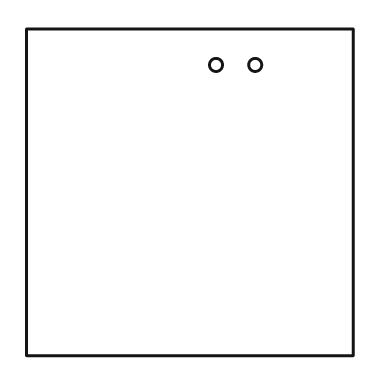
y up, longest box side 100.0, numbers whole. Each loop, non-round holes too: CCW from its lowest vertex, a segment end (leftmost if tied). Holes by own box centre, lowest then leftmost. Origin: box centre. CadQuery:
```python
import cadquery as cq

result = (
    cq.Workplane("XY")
    .moveTo(-50.0, -50.0)
    .lineTo(50.0, -50.0)
    .lineTo(50.0, 50.0)
    .lineTo(-50.0, 50.0)
    .close()
    .moveTo(8.0, 39.0)
    .circle(2.0)
    .moveTo(20.0, 39.0)
    .circle(2.0)
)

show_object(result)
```